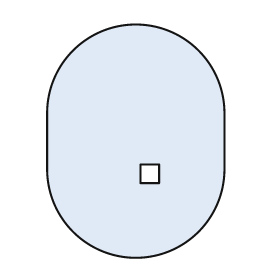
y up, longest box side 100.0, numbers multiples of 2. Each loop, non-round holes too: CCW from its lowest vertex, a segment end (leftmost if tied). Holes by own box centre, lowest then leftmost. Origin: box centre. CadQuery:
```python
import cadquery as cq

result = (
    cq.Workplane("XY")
    .moveTo(-38.0, -12.0)
    .threePointArc((0.0, -50.0), (38.0, -12.0))
    .lineTo(38.0, 12.0)
    .threePointArc((0.0, 50.0), (-38.0, 12.0))
    .close()
    .moveTo(2.0, -18.0)
    .lineTo(10.0, -18.0)
    .lineTo(10.0, -10.0)
    .lineTo(2.0, -10.0)
    .close()
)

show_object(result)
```